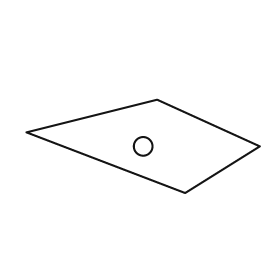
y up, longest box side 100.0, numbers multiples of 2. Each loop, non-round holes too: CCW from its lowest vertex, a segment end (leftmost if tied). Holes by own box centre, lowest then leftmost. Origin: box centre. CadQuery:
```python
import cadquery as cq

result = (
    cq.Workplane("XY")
    .moveTo(18.0, -20.0)
    .lineTo(50.0, 0.0)
    .lineTo(6.0, 20.0)
    .lineTo(-50.0, 6.0)
    .close()
    .moveTo(0.0, 0.0)
    .circle(4.0)
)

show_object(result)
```